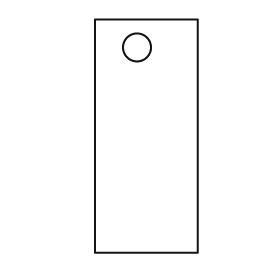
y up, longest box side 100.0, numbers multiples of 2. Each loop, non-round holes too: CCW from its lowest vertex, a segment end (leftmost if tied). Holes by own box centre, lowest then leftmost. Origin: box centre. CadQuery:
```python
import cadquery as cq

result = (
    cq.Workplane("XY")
    .moveTo(-22.0, -50.0)
    .lineTo(22.0, -50.0)
    .lineTo(22.0, 50.0)
    .lineTo(-22.0, 50.0)
    .close()
    .moveTo(-4.0, 38.0)
    .circle(6.0)
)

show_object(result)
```